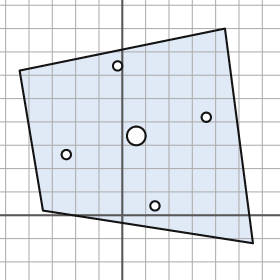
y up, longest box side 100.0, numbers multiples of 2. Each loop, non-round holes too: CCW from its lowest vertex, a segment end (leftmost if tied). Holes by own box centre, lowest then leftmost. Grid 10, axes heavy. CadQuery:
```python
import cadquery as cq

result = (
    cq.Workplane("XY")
    .moveTo(56.0, -12.0)
    .lineTo(44.0, 80.0)
    .lineTo(-44.0, 62.0)
    .lineTo(-34.0, 2.0)
    .close()
    .moveTo(14.0, 4.0)
    .circle(2.0)
    .moveTo(-24.0, 26.0)
    .circle(2.0)
    .moveTo(6.0, 34.0)
    .circle(4.0)
    .moveTo(36.0, 42.0)
    .circle(2.0)
    .moveTo(-2.0, 64.0)
    .circle(2.0)
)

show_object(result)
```